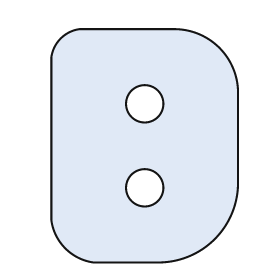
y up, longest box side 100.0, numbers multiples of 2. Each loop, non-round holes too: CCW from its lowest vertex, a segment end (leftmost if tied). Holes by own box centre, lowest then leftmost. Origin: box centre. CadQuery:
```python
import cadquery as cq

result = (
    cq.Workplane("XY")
    .moveTo(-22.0, -50.0)
    .lineTo(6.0, -50.0)
    .threePointArc((30.0, -40.0), (40.0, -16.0))
    .lineTo(40.0, 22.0)
    .threePointArc((32.0, 42.0), (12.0, 50.0))
    .lineTo(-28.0, 50.0)
    .threePointArc((-36.0, 46.0), (-40.0, 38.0))
    .lineTo(-40.0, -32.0)
    .threePointArc((-34.0, -44.0), (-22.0, -50.0))
    .close()
    .moveTo(0.0, -18.0)
    .circle(8.0)
    .moveTo(0.0, 18.0)
    .circle(8.0)
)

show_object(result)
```